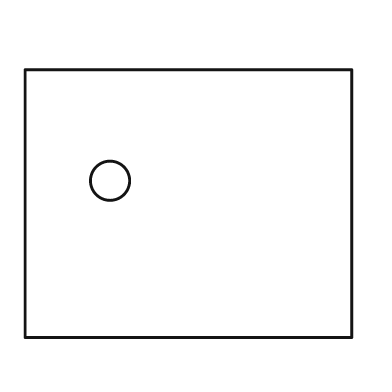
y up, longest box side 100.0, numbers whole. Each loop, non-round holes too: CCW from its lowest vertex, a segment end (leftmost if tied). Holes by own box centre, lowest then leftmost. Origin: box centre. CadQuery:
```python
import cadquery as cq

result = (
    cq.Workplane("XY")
    .moveTo(-50.0, -41.0)
    .lineTo(50.0, -41.0)
    .lineTo(50.0, 41.0)
    .lineTo(-50.0, 41.0)
    .close()
    .moveTo(-24.0, 7.0)
    .circle(6.0)
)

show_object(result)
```